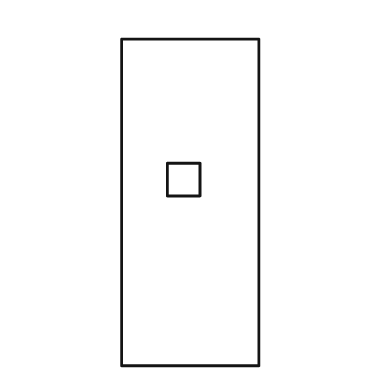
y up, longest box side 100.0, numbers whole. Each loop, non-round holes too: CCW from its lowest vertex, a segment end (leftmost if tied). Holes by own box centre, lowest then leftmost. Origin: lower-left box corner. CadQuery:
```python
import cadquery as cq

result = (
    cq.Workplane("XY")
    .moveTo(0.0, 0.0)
    .lineTo(42.0, 0.0)
    .lineTo(42.0, 100.0)
    .lineTo(0.0, 100.0)
    .close()
    .moveTo(14.0, 52.0)
    .lineTo(24.0, 52.0)
    .lineTo(24.0, 62.0)
    .lineTo(14.0, 62.0)
    .close()
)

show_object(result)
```